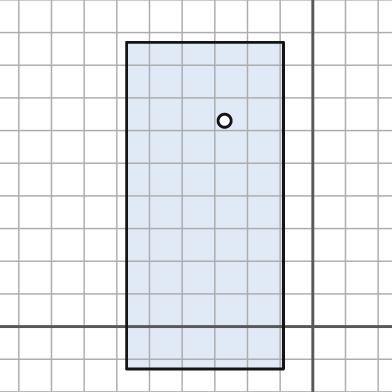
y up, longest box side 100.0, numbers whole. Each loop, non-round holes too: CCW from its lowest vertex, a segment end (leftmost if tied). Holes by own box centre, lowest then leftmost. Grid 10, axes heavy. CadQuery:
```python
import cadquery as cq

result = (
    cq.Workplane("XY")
    .moveTo(-57.0, -13.0)
    .lineTo(-9.0, -13.0)
    .lineTo(-9.0, 87.0)
    .lineTo(-57.0, 87.0)
    .close()
    .moveTo(-27.0, 63.0)
    .circle(2.0)
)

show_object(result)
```